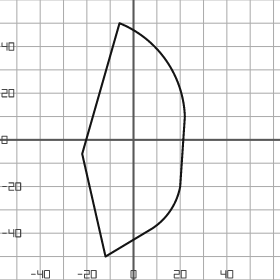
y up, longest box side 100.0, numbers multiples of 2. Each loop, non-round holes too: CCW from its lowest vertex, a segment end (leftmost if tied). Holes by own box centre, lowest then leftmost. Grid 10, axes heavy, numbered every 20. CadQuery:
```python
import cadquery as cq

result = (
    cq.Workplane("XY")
    .moveTo(-12.0, -50.0)
    .lineTo(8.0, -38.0)
    .threePointArc((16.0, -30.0), (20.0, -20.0))
    .lineTo(22.0, 10.0)
    .threePointArc((14.0, 34.0), (-6.0, 50.0))
    .lineTo(-22.0, -6.0)
    .close()
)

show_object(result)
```